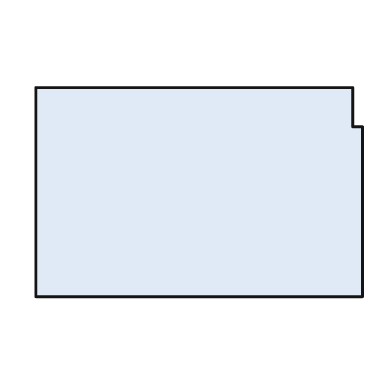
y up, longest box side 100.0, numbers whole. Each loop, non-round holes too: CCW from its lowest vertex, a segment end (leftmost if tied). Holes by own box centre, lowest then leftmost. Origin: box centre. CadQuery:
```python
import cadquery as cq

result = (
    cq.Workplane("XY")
    .moveTo(-50.0, -32.0)
    .lineTo(50.0, -32.0)
    .lineTo(50.0, 20.0)
    .lineTo(47.0, 20.0)
    .lineTo(47.0, 32.0)
    .lineTo(-50.0, 32.0)
    .close()
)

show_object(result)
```